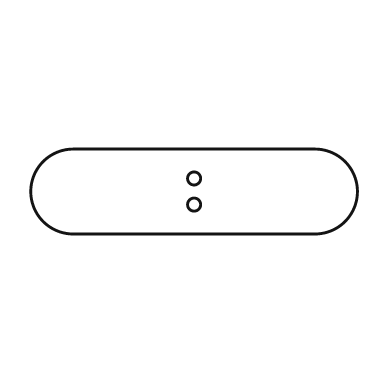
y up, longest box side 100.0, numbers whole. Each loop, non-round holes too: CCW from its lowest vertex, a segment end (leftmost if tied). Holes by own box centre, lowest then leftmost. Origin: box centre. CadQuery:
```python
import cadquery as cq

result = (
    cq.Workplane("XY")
    .moveTo(-37.0, -13.0)
    .lineTo(37.0, -13.0)
    .threePointArc((50.0, 0.0), (37.0, 13.0))
    .lineTo(-37.0, 13.0)
    .threePointArc((-50.0, 0.0), (-37.0, -13.0))
    .close()
    .moveTo(0.0, -4.0)
    .circle(2.0)
    .moveTo(0.0, 4.0)
    .circle(2.0)
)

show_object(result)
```